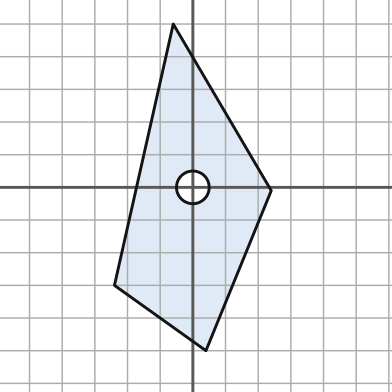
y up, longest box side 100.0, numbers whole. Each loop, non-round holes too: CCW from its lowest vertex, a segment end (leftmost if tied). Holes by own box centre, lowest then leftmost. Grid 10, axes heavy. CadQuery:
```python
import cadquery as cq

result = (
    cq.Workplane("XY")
    .moveTo(4.0, -50.0)
    .lineTo(24.0, -1.0)
    .lineTo(-6.0, 50.0)
    .lineTo(-24.0, -30.0)
    .close()
    .moveTo(0.0, 0.0)
    .circle(5.0)
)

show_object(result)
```